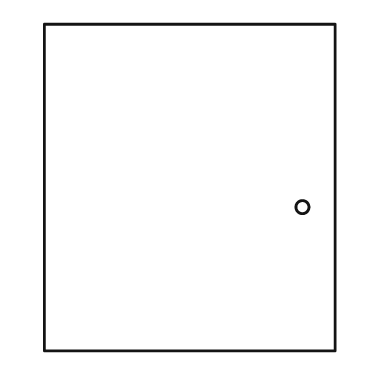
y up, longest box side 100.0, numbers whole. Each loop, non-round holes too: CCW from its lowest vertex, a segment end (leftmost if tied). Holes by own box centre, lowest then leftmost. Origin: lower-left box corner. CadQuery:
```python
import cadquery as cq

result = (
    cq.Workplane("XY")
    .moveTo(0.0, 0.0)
    .lineTo(89.0, 0.0)
    .lineTo(89.0, 100.0)
    .lineTo(0.0, 100.0)
    .close()
    .moveTo(79.0, 44.0)
    .circle(2.0)
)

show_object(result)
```